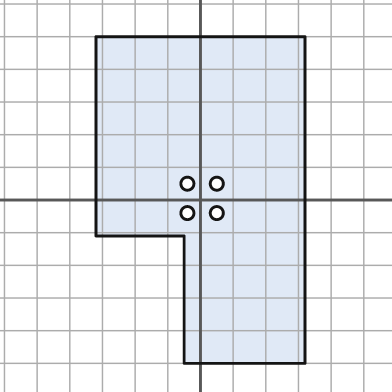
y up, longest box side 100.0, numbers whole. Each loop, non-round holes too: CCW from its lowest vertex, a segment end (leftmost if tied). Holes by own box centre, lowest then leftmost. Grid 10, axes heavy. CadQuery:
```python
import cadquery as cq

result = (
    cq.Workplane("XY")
    .moveTo(-5.0, -50.0)
    .lineTo(32.0, -50.0)
    .lineTo(32.0, 50.0)
    .lineTo(-32.0, 50.0)
    .lineTo(-32.0, -11.0)
    .lineTo(-5.0, -11.0)
    .close()
    .moveTo(-4.0, -4.0)
    .circle(2.0)
    .moveTo(5.0, -4.0)
    .circle(2.0)
    .moveTo(-4.0, 5.0)
    .circle(2.0)
    .moveTo(5.0, 5.0)
    .circle(2.0)
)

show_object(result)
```